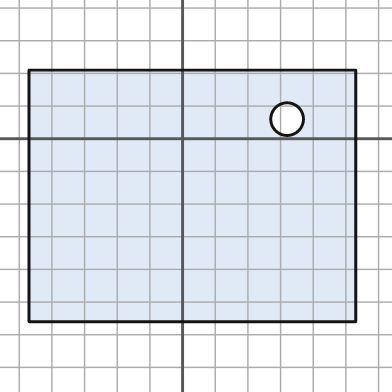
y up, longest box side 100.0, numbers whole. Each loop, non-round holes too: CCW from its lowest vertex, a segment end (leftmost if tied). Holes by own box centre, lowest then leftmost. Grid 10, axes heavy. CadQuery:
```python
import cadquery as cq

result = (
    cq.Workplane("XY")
    .moveTo(-47.0, -56.0)
    .lineTo(53.0, -56.0)
    .lineTo(53.0, 21.0)
    .lineTo(-47.0, 21.0)
    .close()
    .moveTo(32.0, 6.0)
    .circle(5.0)
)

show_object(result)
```